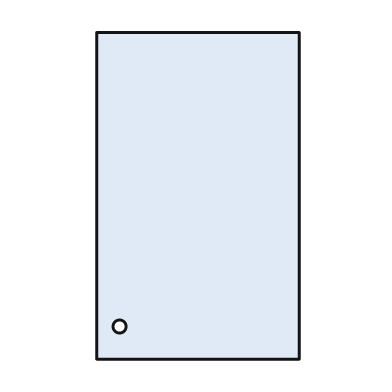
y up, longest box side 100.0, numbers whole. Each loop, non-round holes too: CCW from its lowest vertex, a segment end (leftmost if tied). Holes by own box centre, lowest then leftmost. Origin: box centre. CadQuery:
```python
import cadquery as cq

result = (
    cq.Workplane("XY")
    .moveTo(-31.0, -50.0)
    .lineTo(31.0, -50.0)
    .lineTo(31.0, 50.0)
    .lineTo(-31.0, 50.0)
    .close()
    .moveTo(-24.0, -40.0)
    .circle(2.0)
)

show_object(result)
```